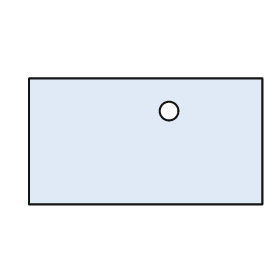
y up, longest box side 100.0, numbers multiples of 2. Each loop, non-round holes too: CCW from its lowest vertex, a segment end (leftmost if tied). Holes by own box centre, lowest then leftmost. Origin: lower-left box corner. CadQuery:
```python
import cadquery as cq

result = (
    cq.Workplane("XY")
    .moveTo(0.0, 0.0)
    .lineTo(100.0, 0.0)
    .lineTo(100.0, 54.0)
    .lineTo(0.0, 54.0)
    .close()
    .moveTo(60.0, 40.0)
    .circle(4.0)
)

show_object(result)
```